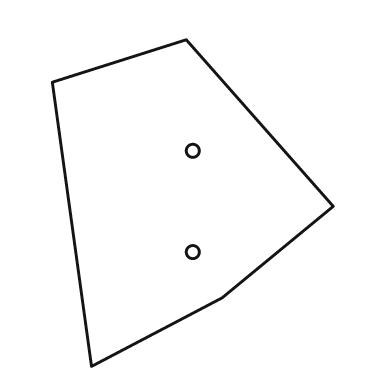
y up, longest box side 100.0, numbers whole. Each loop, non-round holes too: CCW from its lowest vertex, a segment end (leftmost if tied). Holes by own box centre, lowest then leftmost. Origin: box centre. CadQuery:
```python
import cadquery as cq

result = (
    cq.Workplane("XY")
    .moveTo(-31.0, -50.0)
    .lineTo(9.0, -29.0)
    .lineTo(43.0, -1.0)
    .lineTo(-2.0, 50.0)
    .lineTo(-43.0, 37.0)
    .close()
    .moveTo(0.0, -15.0)
    .circle(2.0)
    .moveTo(0.0, 16.0)
    .circle(2.0)
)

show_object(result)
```